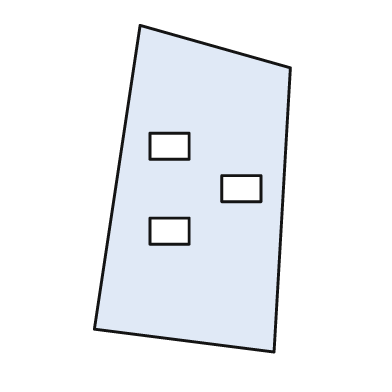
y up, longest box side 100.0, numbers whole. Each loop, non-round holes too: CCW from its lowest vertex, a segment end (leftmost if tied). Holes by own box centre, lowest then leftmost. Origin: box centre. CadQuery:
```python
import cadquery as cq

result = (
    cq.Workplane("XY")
    .moveTo(25.0, -50.0)
    .lineTo(30.0, 37.0)
    .lineTo(-16.0, 50.0)
    .lineTo(-30.0, -43.0)
    .close()
    .moveTo(-13.0, -17.0)
    .lineTo(-1.0, -17.0)
    .lineTo(-1.0, -9.0)
    .lineTo(-13.0, -9.0)
    .close()
    .moveTo(9.0, -4.0)
    .lineTo(21.0, -4.0)
    .lineTo(21.0, 4.0)
    .lineTo(9.0, 4.0)
    .close()
    .moveTo(-13.0, 9.0)
    .lineTo(-1.0, 9.0)
    .lineTo(-1.0, 17.0)
    .lineTo(-13.0, 17.0)
    .close()
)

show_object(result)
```